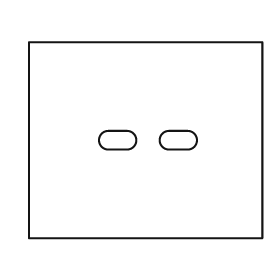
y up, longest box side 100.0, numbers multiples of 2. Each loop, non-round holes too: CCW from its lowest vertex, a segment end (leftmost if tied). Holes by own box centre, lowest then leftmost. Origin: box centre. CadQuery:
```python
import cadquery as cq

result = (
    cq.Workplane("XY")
    .moveTo(-50.0, -42.0)
    .lineTo(50.0, -42.0)
    .lineTo(50.0, 42.0)
    .lineTo(-50.0, 42.0)
    .close()
    .moveTo(-16.0, -4.0)
    .lineTo(-8.0, -4.0)
    .threePointArc((-4.0, 0.0), (-8.0, 4.0))
    .lineTo(-16.0, 4.0)
    .threePointArc((-20.0, 0.0), (-16.0, -4.0))
    .close()
    .moveTo(10.0, -4.0)
    .lineTo(18.0, -4.0)
    .threePointArc((22.0, 0.0), (18.0, 4.0))
    .lineTo(10.0, 4.0)
    .threePointArc((6.0, 0.0), (10.0, -4.0))
    .close()
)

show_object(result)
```